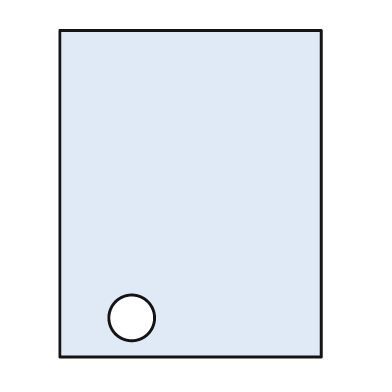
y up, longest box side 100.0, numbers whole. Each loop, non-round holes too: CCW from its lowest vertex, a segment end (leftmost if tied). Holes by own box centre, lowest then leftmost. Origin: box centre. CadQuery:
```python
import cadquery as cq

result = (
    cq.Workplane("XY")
    .moveTo(-40.0, -50.0)
    .lineTo(40.0, -50.0)
    .lineTo(40.0, 50.0)
    .lineTo(-40.0, 50.0)
    .close()
    .moveTo(-18.0, -38.0)
    .circle(7.0)
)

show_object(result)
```